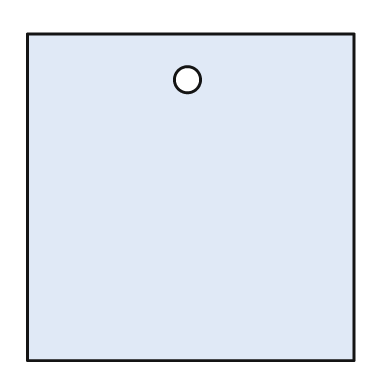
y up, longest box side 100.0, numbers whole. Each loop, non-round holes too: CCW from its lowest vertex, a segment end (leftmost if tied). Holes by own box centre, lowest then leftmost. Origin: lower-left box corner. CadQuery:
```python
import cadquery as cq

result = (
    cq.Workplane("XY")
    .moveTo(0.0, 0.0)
    .lineTo(100.0, 0.0)
    .lineTo(100.0, 100.0)
    .lineTo(0.0, 100.0)
    .close()
    .moveTo(49.0, 86.0)
    .circle(4.0)
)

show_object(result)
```